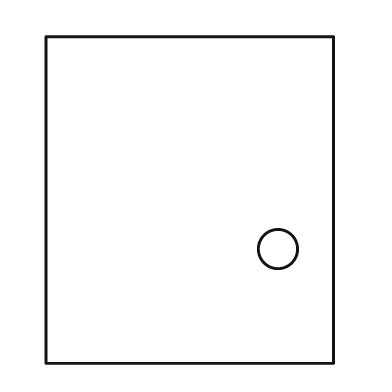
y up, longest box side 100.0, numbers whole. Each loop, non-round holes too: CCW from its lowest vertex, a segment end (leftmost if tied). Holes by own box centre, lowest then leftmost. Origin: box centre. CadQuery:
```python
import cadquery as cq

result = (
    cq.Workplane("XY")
    .moveTo(-44.0, -50.0)
    .lineTo(44.0, -50.0)
    .lineTo(44.0, 50.0)
    .lineTo(-44.0, 50.0)
    .close()
    .moveTo(27.0, -15.0)
    .circle(6.0)
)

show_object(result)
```